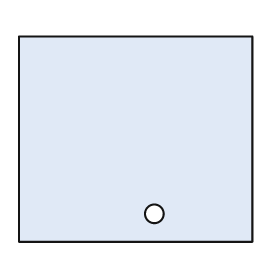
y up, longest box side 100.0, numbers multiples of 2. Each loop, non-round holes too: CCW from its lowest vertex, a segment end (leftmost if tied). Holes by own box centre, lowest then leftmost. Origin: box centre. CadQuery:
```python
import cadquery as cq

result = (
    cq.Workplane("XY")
    .moveTo(-50.0, -44.0)
    .lineTo(50.0, -44.0)
    .lineTo(50.0, 44.0)
    .lineTo(-50.0, 44.0)
    .close()
    .moveTo(8.0, -32.0)
    .circle(4.0)
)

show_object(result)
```